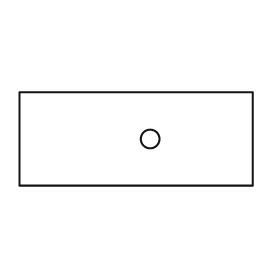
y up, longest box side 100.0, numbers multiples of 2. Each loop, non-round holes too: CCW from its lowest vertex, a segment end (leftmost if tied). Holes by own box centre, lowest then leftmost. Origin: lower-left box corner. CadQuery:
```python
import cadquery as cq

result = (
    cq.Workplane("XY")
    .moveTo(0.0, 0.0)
    .lineTo(100.0, 0.0)
    .lineTo(100.0, 40.0)
    .lineTo(0.0, 40.0)
    .close()
    .moveTo(56.0, 20.0)
    .circle(4.0)
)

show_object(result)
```